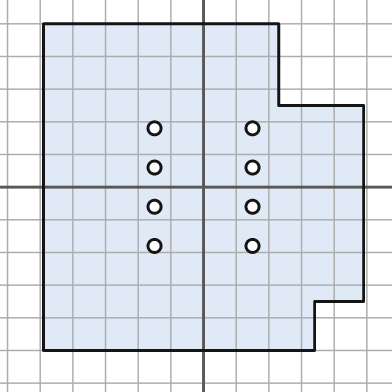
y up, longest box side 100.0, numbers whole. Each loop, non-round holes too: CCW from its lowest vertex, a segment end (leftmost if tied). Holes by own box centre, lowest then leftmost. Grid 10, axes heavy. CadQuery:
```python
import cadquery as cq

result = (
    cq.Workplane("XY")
    .moveTo(-49.0, -50.0)
    .lineTo(34.0, -50.0)
    .lineTo(34.0, -35.0)
    .lineTo(49.0, -35.0)
    .lineTo(49.0, 25.0)
    .lineTo(23.0, 25.0)
    .lineTo(23.0, 50.0)
    .lineTo(-49.0, 50.0)
    .close()
    .moveTo(-15.0, -18.0)
    .circle(2.0)
    .moveTo(15.0, -18.0)
    .circle(2.0)
    .moveTo(-15.0, -6.0)
    .circle(2.0)
    .moveTo(15.0, -6.0)
    .circle(2.0)
    .moveTo(-15.0, 6.0)
    .circle(2.0)
    .moveTo(15.0, 6.0)
    .circle(2.0)
    .moveTo(-15.0, 18.0)
    .circle(2.0)
    .moveTo(15.0, 18.0)
    .circle(2.0)
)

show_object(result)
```